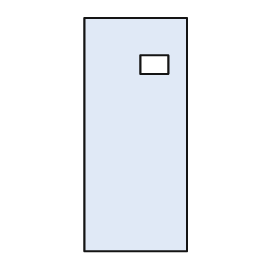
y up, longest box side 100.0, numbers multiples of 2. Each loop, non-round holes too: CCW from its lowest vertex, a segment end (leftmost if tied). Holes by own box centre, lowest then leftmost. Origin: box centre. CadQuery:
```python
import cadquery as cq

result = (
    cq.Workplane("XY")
    .moveTo(-22.0, -50.0)
    .lineTo(22.0, -50.0)
    .lineTo(22.0, 50.0)
    .lineTo(-22.0, 50.0)
    .close()
    .moveTo(2.0, 26.0)
    .lineTo(14.0, 26.0)
    .lineTo(14.0, 34.0)
    .lineTo(2.0, 34.0)
    .close()
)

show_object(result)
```